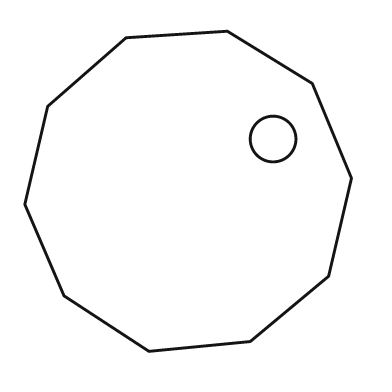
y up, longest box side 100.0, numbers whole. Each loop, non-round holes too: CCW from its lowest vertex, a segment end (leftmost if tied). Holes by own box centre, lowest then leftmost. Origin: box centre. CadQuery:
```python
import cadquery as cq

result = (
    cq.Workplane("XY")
    .moveTo(-12.0, -49.0)
    .lineTo(19.0, -46.0)
    .lineTo(43.0, -26.0)
    .lineTo(50.0, 4.0)
    .lineTo(38.0, 33.0)
    .lineTo(12.0, 49.0)
    .lineTo(-19.0, 47.0)
    .lineTo(-43.0, 26.0)
    .lineTo(-50.0, -4.0)
    .lineTo(-38.0, -32.0)
    .close()
    .moveTo(26.0, 16.0)
    .circle(7.0)
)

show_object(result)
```